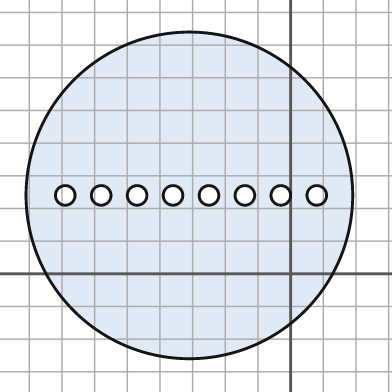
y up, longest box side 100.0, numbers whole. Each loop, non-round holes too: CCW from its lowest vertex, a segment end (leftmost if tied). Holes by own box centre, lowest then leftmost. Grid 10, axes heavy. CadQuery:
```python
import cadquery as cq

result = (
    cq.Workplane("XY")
    .moveTo(-31.0, 24.0)
    .circle(50.0)
    .moveTo(-69.0, 24.0)
    .circle(3.0)
    .moveTo(-58.0, 24.0)
    .circle(3.0)
    .moveTo(-47.0, 24.0)
    .circle(3.0)
    .moveTo(-36.0, 24.0)
    .circle(3.0)
    .moveTo(-25.0, 24.0)
    .circle(3.0)
    .moveTo(-14.0, 24.0)
    .circle(3.0)
    .moveTo(-3.0, 24.0)
    .circle(3.0)
    .moveTo(8.0, 24.0)
    .circle(3.0)
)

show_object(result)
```